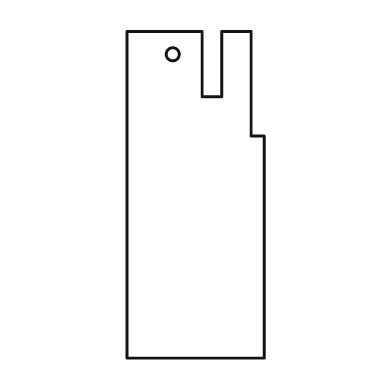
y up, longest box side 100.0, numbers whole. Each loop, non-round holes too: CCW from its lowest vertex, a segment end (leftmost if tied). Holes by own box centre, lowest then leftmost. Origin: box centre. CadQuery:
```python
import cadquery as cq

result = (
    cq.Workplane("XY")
    .moveTo(-21.0, -50.0)
    .lineTo(21.0, -50.0)
    .lineTo(21.0, 18.0)
    .lineTo(17.0, 18.0)
    .lineTo(17.0, 50.0)
    .lineTo(8.0, 50.0)
    .lineTo(8.0, 30.0)
    .lineTo(2.0, 30.0)
    .lineTo(2.0, 50.0)
    .lineTo(-21.0, 50.0)
    .close()
    .moveTo(-7.0, 43.0)
    .circle(2.0)
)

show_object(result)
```